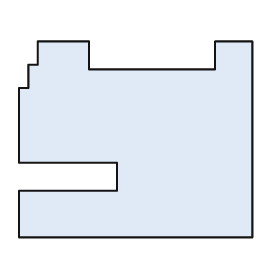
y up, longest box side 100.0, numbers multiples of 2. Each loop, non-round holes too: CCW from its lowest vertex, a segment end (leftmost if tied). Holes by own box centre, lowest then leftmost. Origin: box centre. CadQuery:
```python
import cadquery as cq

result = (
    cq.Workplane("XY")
    .moveTo(-50.0, -42.0)
    .lineTo(50.0, -42.0)
    .lineTo(50.0, 42.0)
    .lineTo(34.0, 42.0)
    .lineTo(34.0, 30.0)
    .lineTo(-20.0, 30.0)
    .lineTo(-20.0, 42.0)
    .lineTo(-42.0, 42.0)
    .lineTo(-42.0, 32.0)
    .lineTo(-46.0, 32.0)
    .lineTo(-46.0, 22.0)
    .lineTo(-50.0, 22.0)
    .lineTo(-50.0, -10.0)
    .lineTo(-8.0, -10.0)
    .lineTo(-8.0, -22.0)
    .lineTo(-50.0, -22.0)
    .close()
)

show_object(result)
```